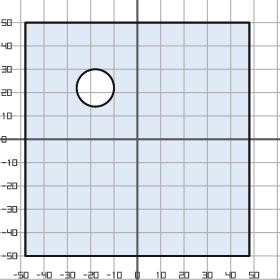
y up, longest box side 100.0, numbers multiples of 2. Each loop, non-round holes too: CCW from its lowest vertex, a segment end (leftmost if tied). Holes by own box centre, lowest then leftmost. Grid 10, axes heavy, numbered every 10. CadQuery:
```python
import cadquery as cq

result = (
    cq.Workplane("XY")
    .moveTo(-48.0, -50.0)
    .lineTo(48.0, -50.0)
    .lineTo(48.0, 50.0)
    .lineTo(-48.0, 50.0)
    .close()
    .moveTo(-18.0, 22.0)
    .circle(8.0)
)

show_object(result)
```